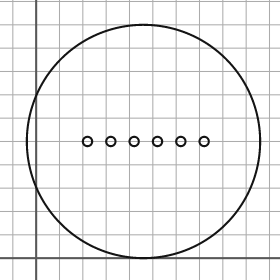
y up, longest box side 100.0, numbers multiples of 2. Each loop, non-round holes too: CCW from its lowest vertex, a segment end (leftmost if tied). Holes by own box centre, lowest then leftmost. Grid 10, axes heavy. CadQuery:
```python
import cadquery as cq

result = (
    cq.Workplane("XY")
    .moveTo(46.0, 50.0)
    .circle(50.0)
    .moveTo(22.0, 50.0)
    .circle(2.0)
    .moveTo(32.0, 50.0)
    .circle(2.0)
    .moveTo(42.0, 50.0)
    .circle(2.0)
    .moveTo(52.0, 50.0)
    .circle(2.0)
    .moveTo(62.0, 50.0)
    .circle(2.0)
    .moveTo(72.0, 50.0)
    .circle(2.0)
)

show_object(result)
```